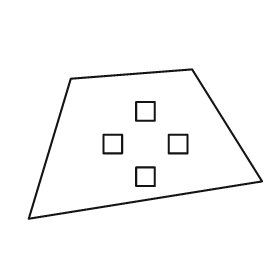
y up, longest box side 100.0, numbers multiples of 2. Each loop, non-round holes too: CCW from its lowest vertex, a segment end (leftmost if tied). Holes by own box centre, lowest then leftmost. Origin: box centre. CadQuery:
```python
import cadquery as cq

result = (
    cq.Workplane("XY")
    .moveTo(-50.0, -32.0)
    .lineTo(50.0, -16.0)
    .lineTo(20.0, 32.0)
    .lineTo(-32.0, 28.0)
    .close()
    .moveTo(-4.0, -18.0)
    .lineTo(4.0, -18.0)
    .lineTo(4.0, -10.0)
    .lineTo(-4.0, -10.0)
    .close()
    .moveTo(-18.0, -4.0)
    .lineTo(-10.0, -4.0)
    .lineTo(-10.0, 4.0)
    .lineTo(-18.0, 4.0)
    .close()
    .moveTo(10.0, -4.0)
    .lineTo(18.0, -4.0)
    .lineTo(18.0, 4.0)
    .lineTo(10.0, 4.0)
    .close()
    .moveTo(-4.0, 10.0)
    .lineTo(4.0, 10.0)
    .lineTo(4.0, 18.0)
    .lineTo(-4.0, 18.0)
    .close()
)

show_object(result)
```